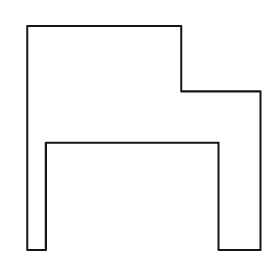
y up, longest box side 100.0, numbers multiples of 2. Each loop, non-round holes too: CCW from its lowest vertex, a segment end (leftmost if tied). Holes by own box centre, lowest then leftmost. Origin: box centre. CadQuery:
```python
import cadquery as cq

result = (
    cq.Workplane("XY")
    .moveTo(-50.0, -48.0)
    .lineTo(-42.0, -48.0)
    .lineTo(-42.0, -2.0)
    .lineTo(32.0, -2.0)
    .lineTo(32.0, -48.0)
    .lineTo(50.0, -48.0)
    .lineTo(50.0, 20.0)
    .lineTo(16.0, 20.0)
    .lineTo(16.0, 48.0)
    .lineTo(-50.0, 48.0)
    .close()
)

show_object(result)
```